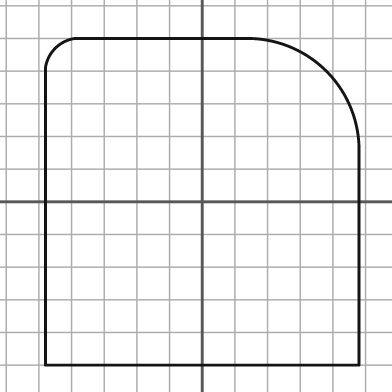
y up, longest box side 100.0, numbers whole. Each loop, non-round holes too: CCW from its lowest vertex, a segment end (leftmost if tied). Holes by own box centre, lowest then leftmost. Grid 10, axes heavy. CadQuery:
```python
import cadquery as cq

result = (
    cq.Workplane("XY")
    .moveTo(-48.0, -50.0)
    .lineTo(48.0, -50.0)
    .lineTo(48.0, 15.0)
    .threePointArc((38.0, 40.0), (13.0, 50.0))
    .lineTo(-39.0, 50.0)
    .threePointArc((-45.0, 47.0), (-48.0, 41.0))
    .close()
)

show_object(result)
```